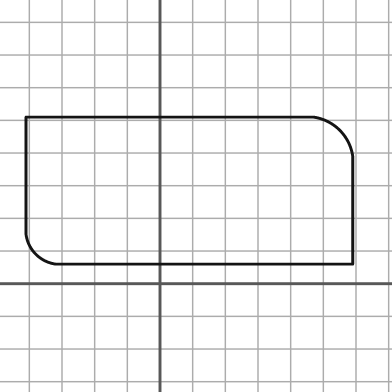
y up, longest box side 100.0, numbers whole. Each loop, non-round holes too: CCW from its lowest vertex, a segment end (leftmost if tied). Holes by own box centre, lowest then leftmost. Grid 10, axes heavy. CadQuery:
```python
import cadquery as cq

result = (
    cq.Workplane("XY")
    .moveTo(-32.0, 6.0)
    .lineTo(59.0, 6.0)
    .lineTo(59.0, 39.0)
    .threePointArc((55.0, 47.0), (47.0, 51.0))
    .lineTo(-41.0, 51.0)
    .lineTo(-41.0, 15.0)
    .threePointArc((-38.0, 9.0), (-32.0, 6.0))
    .close()
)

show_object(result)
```